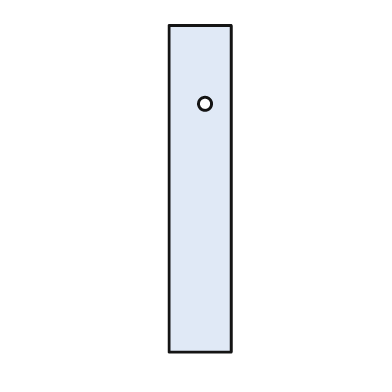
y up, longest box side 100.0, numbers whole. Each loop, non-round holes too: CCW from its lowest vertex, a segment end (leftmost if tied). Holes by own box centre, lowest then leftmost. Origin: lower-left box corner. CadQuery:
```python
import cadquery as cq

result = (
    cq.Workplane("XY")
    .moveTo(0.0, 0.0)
    .lineTo(19.0, 0.0)
    .lineTo(19.0, 100.0)
    .lineTo(0.0, 100.0)
    .close()
    .moveTo(11.0, 76.0)
    .circle(2.0)
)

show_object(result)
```